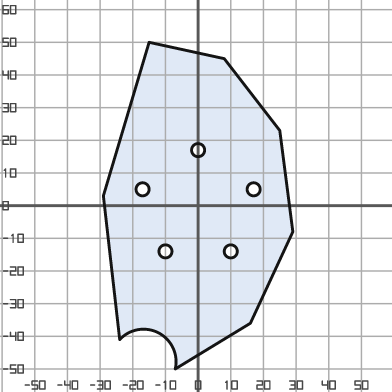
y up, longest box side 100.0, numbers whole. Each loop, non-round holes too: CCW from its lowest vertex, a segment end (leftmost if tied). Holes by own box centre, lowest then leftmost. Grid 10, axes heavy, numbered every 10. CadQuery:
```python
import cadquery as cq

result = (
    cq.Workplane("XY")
    .moveTo(-7.0, -50.0)
    .lineTo(16.0, -36.0)
    .lineTo(29.0, -8.0)
    .lineTo(25.0, 23.0)
    .lineTo(8.0, 45.0)
    .lineTo(-15.0, 50.0)
    .lineTo(-29.0, 3.0)
    .lineTo(-24.0, -41.0)
    .threePointArc((-12.0, -39.0), (-7.0, -50.0))
    .close()
    .moveTo(-10.0, -14.0)
    .circle(2.0)
    .moveTo(10.0, -14.0)
    .circle(2.0)
    .moveTo(-17.0, 5.0)
    .circle(2.0)
    .moveTo(17.0, 5.0)
    .circle(2.0)
    .moveTo(0.0, 17.0)
    .circle(2.0)
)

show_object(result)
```